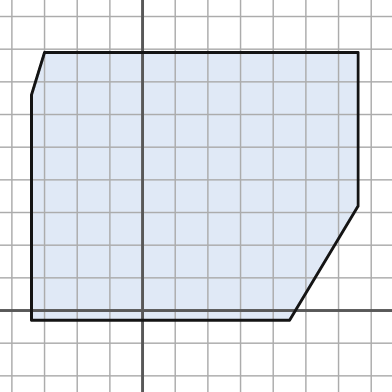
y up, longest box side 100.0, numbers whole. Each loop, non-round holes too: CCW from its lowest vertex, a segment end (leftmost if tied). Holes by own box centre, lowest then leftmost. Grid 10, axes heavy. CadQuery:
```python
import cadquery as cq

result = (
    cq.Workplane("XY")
    .moveTo(-34.0, -3.0)
    .lineTo(45.0, -3.0)
    .lineTo(66.0, 32.0)
    .lineTo(66.0, 79.0)
    .lineTo(-30.0, 79.0)
    .lineTo(-34.0, 66.0)
    .close()
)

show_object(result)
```